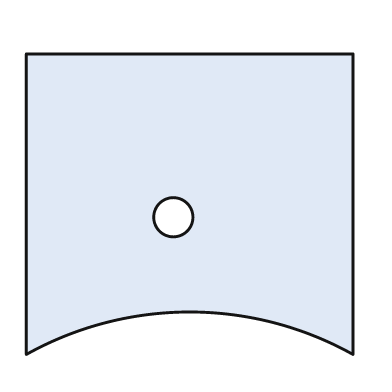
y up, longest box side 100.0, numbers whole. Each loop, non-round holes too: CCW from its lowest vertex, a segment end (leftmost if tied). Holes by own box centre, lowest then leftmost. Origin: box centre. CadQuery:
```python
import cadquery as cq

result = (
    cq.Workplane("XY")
    .moveTo(-50.0, -46.0)
    .threePointArc((0.0, -33.0), (50.0, -46.0))
    .lineTo(50.0, 46.0)
    .lineTo(-50.0, 46.0)
    .close()
    .moveTo(-5.0, -4.0)
    .circle(6.0)
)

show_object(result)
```